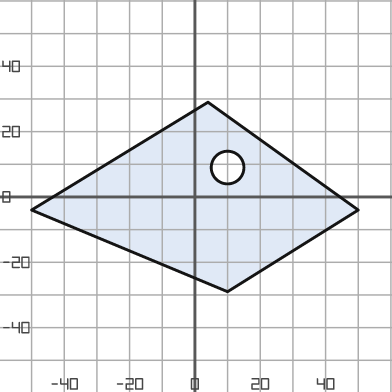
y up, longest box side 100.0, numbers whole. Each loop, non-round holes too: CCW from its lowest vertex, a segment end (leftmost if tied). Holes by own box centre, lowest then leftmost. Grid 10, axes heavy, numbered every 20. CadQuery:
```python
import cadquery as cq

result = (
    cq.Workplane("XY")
    .moveTo(10.0, -29.0)
    .lineTo(50.0, -4.0)
    .lineTo(4.0, 29.0)
    .lineTo(-50.0, -4.0)
    .close()
    .moveTo(10.0, 9.0)
    .circle(5.0)
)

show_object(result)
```